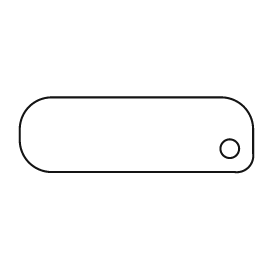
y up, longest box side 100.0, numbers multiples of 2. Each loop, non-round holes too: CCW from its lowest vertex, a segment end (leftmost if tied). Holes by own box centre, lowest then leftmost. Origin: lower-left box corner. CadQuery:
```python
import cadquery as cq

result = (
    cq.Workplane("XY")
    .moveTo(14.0, 0.0)
    .lineTo(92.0, 0.0)
    .threePointArc((98.0, 2.0), (100.0, 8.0))
    .lineTo(100.0, 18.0)
    .threePointArc((96.0, 28.0), (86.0, 32.0))
    .lineTo(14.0, 32.0)
    .threePointArc((4.0, 28.0), (0.0, 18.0))
    .lineTo(0.0, 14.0)
    .threePointArc((4.0, 4.0), (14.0, 0.0))
    .close()
    .moveTo(90.0, 10.0)
    .circle(4.0)
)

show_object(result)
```